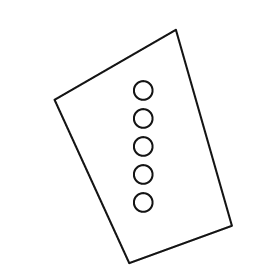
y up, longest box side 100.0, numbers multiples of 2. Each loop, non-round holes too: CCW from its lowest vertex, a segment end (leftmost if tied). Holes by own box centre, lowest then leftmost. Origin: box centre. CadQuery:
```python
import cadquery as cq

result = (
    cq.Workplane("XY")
    .moveTo(-6.0, -50.0)
    .lineTo(38.0, -34.0)
    .lineTo(14.0, 50.0)
    .lineTo(-38.0, 20.0)
    .close()
    .moveTo(0.0, -24.0)
    .circle(4.0)
    .moveTo(0.0, -12.0)
    .circle(4.0)
    .moveTo(0.0, 0.0)
    .circle(4.0)
    .moveTo(0.0, 12.0)
    .circle(4.0)
    .moveTo(0.0, 24.0)
    .circle(4.0)
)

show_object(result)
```